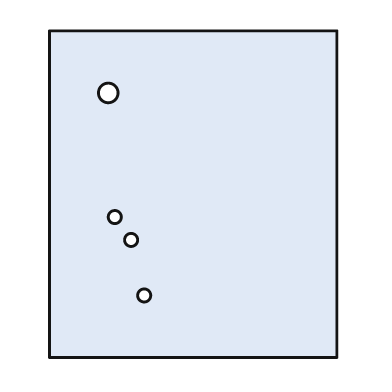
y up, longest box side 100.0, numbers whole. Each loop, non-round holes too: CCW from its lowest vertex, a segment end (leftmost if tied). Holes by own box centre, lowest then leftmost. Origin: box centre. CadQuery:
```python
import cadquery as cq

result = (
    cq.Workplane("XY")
    .moveTo(-44.0, -50.0)
    .lineTo(44.0, -50.0)
    .lineTo(44.0, 50.0)
    .lineTo(-44.0, 50.0)
    .close()
    .moveTo(-15.0, -31.0)
    .circle(2.0)
    .moveTo(-19.0, -14.0)
    .circle(2.0)
    .moveTo(-24.0, -7.0)
    .circle(2.0)
    .moveTo(-26.0, 31.0)
    .circle(3.0)
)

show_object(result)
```